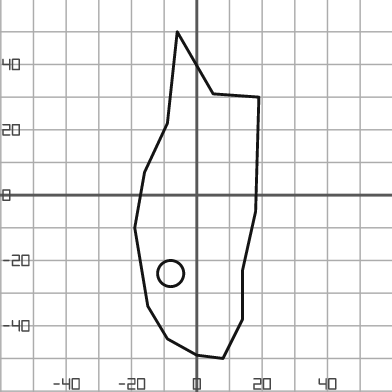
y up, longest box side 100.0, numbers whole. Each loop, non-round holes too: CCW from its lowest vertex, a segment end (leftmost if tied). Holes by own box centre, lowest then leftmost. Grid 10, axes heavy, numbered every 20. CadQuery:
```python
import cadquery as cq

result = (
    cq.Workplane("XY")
    .moveTo(8.0, -50.0)
    .lineTo(14.0, -38.0)
    .lineTo(14.0, -23.0)
    .lineTo(18.0, -5.0)
    .lineTo(19.0, 30.0)
    .lineTo(5.0, 31.0)
    .lineTo(-6.0, 50.0)
    .lineTo(-9.0, 22.0)
    .lineTo(-16.0, 7.0)
    .lineTo(-19.0, -10.0)
    .lineTo(-15.0, -34.0)
    .lineTo(-9.0, -44.0)
    .lineTo(0.0, -49.0)
    .close()
    .moveTo(-8.0, -24.0)
    .circle(4.0)
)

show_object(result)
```